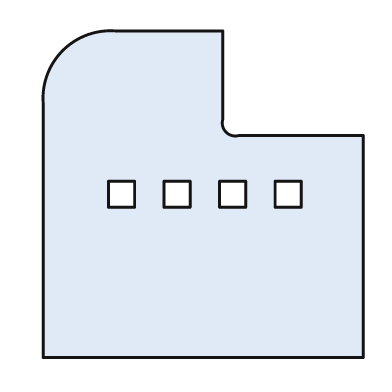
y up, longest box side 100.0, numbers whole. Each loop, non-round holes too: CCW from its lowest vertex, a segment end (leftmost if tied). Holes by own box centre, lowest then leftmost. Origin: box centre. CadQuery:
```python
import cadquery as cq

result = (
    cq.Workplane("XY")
    .moveTo(-49.0, -50.0)
    .lineTo(49.0, -50.0)
    .lineTo(49.0, 18.0)
    .lineTo(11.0, 18.0)
    .threePointArc((7.0, 19.0), (6.0, 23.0))
    .lineTo(6.0, 50.0)
    .lineTo(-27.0, 50.0)
    .threePointArc((-43.0, 44.0), (-49.0, 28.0))
    .close()
    .moveTo(-29.0, -4.0)
    .lineTo(-21.0, -4.0)
    .lineTo(-21.0, 4.0)
    .lineTo(-29.0, 4.0)
    .close()
    .moveTo(-12.0, -4.0)
    .lineTo(-4.0, -4.0)
    .lineTo(-4.0, 4.0)
    .lineTo(-12.0, 4.0)
    .close()
    .moveTo(5.0, -4.0)
    .lineTo(13.0, -4.0)
    .lineTo(13.0, 4.0)
    .lineTo(5.0, 4.0)
    .close()
    .moveTo(22.0, -4.0)
    .lineTo(30.0, -4.0)
    .lineTo(30.0, 4.0)
    .lineTo(22.0, 4.0)
    .close()
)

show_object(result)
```